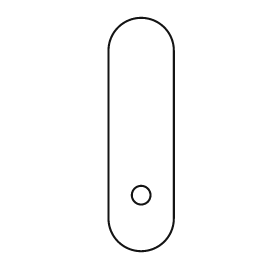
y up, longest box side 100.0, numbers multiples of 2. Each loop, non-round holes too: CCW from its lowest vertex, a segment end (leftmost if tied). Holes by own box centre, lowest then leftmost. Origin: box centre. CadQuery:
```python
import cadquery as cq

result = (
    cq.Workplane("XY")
    .moveTo(-14.0, -36.0)
    .threePointArc((0.0, -50.0), (14.0, -36.0))
    .lineTo(14.0, 36.0)
    .threePointArc((0.0, 50.0), (-14.0, 36.0))
    .close()
    .moveTo(0.0, -26.0)
    .circle(4.0)
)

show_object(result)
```